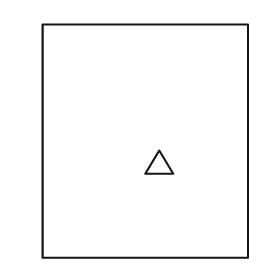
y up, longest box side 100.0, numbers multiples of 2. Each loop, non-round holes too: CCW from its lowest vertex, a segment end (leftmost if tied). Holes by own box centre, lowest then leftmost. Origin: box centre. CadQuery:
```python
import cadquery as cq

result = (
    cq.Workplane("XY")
    .moveTo(-44.0, -50.0)
    .lineTo(44.0, -50.0)
    .lineTo(44.0, 50.0)
    .lineTo(-44.0, 50.0)
    .close()
    .moveTo(0.0, -14.0)
    .lineTo(12.0, -14.0)
    .lineTo(6.0, -4.0)
    .close()
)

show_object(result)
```